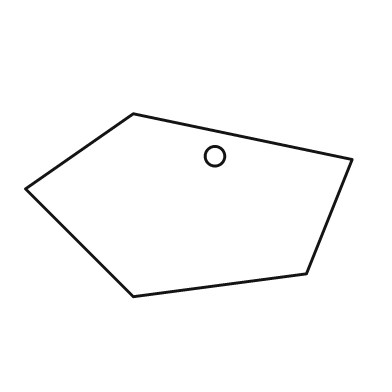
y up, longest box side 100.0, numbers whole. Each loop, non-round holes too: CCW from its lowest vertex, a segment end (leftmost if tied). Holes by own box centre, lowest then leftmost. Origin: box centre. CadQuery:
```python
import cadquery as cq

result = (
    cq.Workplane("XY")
    .moveTo(-17.0, -28.0)
    .lineTo(36.0, -21.0)
    .lineTo(50.0, 14.0)
    .lineTo(-17.0, 28.0)
    .lineTo(-50.0, 5.0)
    .close()
    .moveTo(8.0, 15.0)
    .circle(3.0)
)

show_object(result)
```